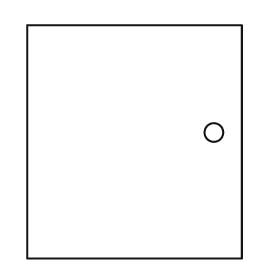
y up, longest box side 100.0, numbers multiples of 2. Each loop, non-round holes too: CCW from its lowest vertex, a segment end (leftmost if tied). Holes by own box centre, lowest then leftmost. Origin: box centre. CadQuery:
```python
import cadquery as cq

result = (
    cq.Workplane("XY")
    .moveTo(-46.0, -50.0)
    .lineTo(46.0, -50.0)
    .lineTo(46.0, 50.0)
    .lineTo(-46.0, 50.0)
    .close()
    .moveTo(34.0, 4.0)
    .circle(4.0)
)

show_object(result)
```